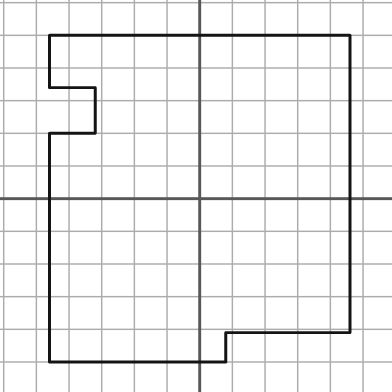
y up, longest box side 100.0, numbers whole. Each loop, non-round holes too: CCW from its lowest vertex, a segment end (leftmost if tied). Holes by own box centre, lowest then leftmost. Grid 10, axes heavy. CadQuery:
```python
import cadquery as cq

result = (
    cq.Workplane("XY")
    .moveTo(-46.0, -50.0)
    .lineTo(8.0, -50.0)
    .lineTo(8.0, -41.0)
    .lineTo(46.0, -41.0)
    .lineTo(46.0, 50.0)
    .lineTo(-46.0, 50.0)
    .lineTo(-46.0, 34.0)
    .lineTo(-32.0, 34.0)
    .lineTo(-32.0, 20.0)
    .lineTo(-46.0, 20.0)
    .close()
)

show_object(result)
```